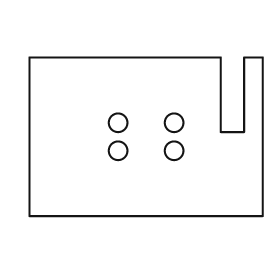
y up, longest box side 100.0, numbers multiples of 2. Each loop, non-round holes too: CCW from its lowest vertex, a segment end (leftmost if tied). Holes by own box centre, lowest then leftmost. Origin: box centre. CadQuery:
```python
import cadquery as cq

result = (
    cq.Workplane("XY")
    .moveTo(-50.0, -34.0)
    .lineTo(50.0, -34.0)
    .lineTo(50.0, 34.0)
    .lineTo(42.0, 34.0)
    .lineTo(42.0, 2.0)
    .lineTo(32.0, 2.0)
    .lineTo(32.0, 34.0)
    .lineTo(-50.0, 34.0)
    .close()
    .moveTo(-12.0, -6.0)
    .circle(4.0)
    .moveTo(12.0, -6.0)
    .circle(4.0)
    .moveTo(-12.0, 6.0)
    .circle(4.0)
    .moveTo(12.0, 6.0)
    .circle(4.0)
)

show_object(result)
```